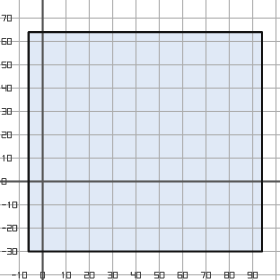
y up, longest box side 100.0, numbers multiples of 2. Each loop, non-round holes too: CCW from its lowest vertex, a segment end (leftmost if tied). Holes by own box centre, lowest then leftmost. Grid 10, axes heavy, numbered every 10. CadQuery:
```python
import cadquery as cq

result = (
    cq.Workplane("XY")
    .moveTo(-6.0, -30.0)
    .lineTo(94.0, -30.0)
    .lineTo(94.0, 64.0)
    .lineTo(-6.0, 64.0)
    .close()
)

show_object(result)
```